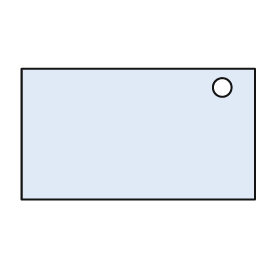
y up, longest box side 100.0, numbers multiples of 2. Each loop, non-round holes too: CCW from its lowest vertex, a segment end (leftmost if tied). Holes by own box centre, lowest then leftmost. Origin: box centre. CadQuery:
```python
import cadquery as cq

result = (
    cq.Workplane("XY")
    .moveTo(-50.0, -28.0)
    .lineTo(50.0, -28.0)
    .lineTo(50.0, 28.0)
    .lineTo(-50.0, 28.0)
    .close()
    .moveTo(36.0, 20.0)
    .circle(4.0)
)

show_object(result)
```